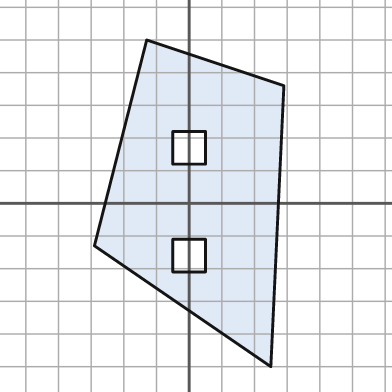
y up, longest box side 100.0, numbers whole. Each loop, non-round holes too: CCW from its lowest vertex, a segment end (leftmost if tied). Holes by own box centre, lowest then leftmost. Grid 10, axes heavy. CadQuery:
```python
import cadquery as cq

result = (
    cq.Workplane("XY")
    .moveTo(25.0, -50.0)
    .lineTo(29.0, 36.0)
    .lineTo(-13.0, 50.0)
    .lineTo(-29.0, -13.0)
    .close()
    .moveTo(-5.0, -21.0)
    .lineTo(5.0, -21.0)
    .lineTo(5.0, -11.0)
    .lineTo(-5.0, -11.0)
    .close()
    .moveTo(-5.0, 12.0)
    .lineTo(5.0, 12.0)
    .lineTo(5.0, 22.0)
    .lineTo(-5.0, 22.0)
    .close()
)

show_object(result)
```